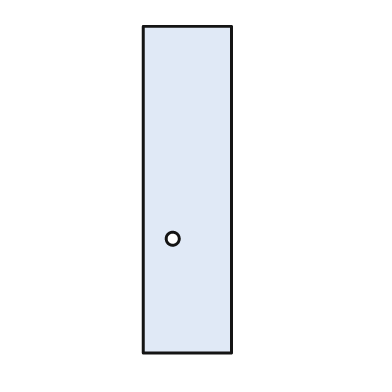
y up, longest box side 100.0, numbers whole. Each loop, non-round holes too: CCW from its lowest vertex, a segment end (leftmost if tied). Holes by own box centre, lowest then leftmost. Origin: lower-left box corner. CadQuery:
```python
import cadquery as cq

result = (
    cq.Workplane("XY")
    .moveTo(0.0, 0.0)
    .lineTo(27.0, 0.0)
    .lineTo(27.0, 100.0)
    .lineTo(0.0, 100.0)
    .close()
    .moveTo(9.0, 35.0)
    .circle(2.0)
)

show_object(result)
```